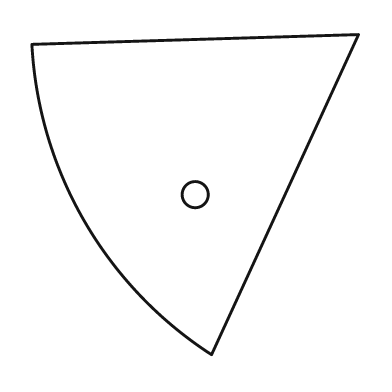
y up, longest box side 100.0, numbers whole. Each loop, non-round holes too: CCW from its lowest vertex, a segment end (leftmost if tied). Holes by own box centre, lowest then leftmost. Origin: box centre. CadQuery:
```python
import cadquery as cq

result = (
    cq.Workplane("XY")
    .moveTo(5.0, -49.0)
    .lineTo(50.0, 49.0)
    .lineTo(-50.0, 46.0)
    .threePointArc((-34.0, -8.0), (5.0, -49.0))
    .close()
    .moveTo(0.0, 0.0)
    .circle(4.0)
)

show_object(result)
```